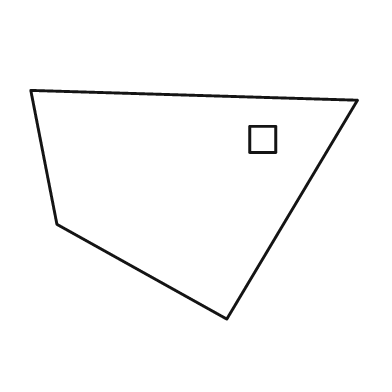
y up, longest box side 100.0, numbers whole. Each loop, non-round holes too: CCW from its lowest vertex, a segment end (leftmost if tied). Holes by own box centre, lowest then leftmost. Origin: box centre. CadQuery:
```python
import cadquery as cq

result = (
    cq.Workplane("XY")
    .moveTo(10.0, -35.0)
    .lineTo(50.0, 32.0)
    .lineTo(-50.0, 35.0)
    .lineTo(-42.0, -6.0)
    .close()
    .moveTo(17.0, 16.0)
    .lineTo(25.0, 16.0)
    .lineTo(25.0, 24.0)
    .lineTo(17.0, 24.0)
    .close()
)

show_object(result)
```